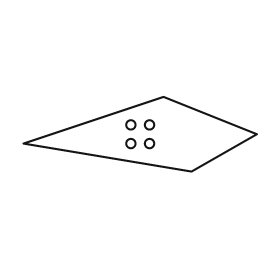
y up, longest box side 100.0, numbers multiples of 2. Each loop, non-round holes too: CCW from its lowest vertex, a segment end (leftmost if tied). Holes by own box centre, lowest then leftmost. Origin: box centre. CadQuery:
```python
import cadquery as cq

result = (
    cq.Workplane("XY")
    .moveTo(22.0, -16.0)
    .lineTo(50.0, 0.0)
    .lineTo(10.0, 16.0)
    .lineTo(-50.0, -4.0)
    .close()
    .moveTo(-4.0, -4.0)
    .circle(2.0)
    .moveTo(4.0, -4.0)
    .circle(2.0)
    .moveTo(-4.0, 4.0)
    .circle(2.0)
    .moveTo(4.0, 4.0)
    .circle(2.0)
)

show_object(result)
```